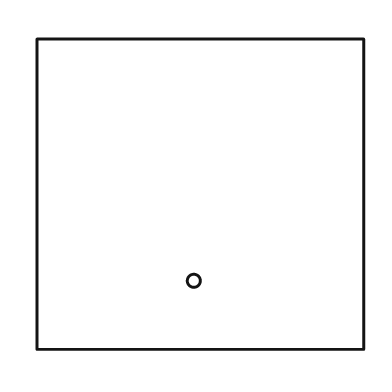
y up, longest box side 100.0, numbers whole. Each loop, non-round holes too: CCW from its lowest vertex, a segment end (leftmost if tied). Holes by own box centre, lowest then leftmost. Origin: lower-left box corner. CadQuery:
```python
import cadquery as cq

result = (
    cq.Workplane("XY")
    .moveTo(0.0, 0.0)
    .lineTo(100.0, 0.0)
    .lineTo(100.0, 95.0)
    .lineTo(0.0, 95.0)
    .close()
    .moveTo(48.0, 21.0)
    .circle(2.0)
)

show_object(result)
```